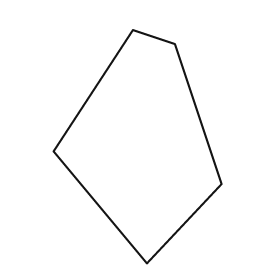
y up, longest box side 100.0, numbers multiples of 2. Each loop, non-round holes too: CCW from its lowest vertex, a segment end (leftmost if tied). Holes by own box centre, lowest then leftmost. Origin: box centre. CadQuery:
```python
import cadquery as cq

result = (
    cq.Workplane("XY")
    .moveTo(4.0, -50.0)
    .lineTo(36.0, -16.0)
    .lineTo(16.0, 44.0)
    .lineTo(-2.0, 50.0)
    .lineTo(-36.0, -2.0)
    .close()
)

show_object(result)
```